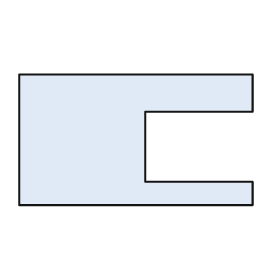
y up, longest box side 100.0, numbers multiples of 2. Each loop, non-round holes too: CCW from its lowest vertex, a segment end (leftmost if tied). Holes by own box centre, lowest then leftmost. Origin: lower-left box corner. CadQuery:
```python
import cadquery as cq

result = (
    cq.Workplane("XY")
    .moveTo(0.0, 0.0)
    .lineTo(100.0, 0.0)
    .lineTo(100.0, 10.0)
    .lineTo(54.0, 10.0)
    .lineTo(54.0, 40.0)
    .lineTo(100.0, 40.0)
    .lineTo(100.0, 56.0)
    .lineTo(0.0, 56.0)
    .close()
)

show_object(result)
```